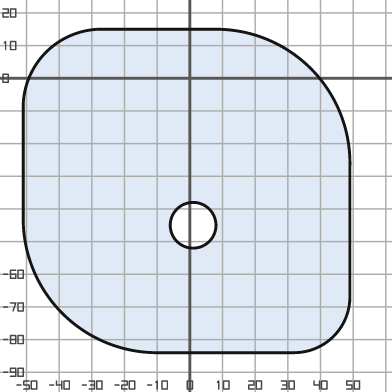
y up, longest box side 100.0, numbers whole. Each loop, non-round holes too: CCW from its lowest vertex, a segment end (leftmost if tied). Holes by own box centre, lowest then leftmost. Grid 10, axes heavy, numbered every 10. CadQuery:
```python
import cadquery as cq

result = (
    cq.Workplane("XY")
    .moveTo(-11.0, -84.0)
    .lineTo(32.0, -84.0)
    .threePointArc((44.0, -79.0), (49.0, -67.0))
    .lineTo(49.0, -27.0)
    .threePointArc((37.0, 3.0), (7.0, 15.0))
    .lineTo(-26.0, 15.0)
    .threePointArc((-44.0, 8.0), (-51.0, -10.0))
    .lineTo(-51.0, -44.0)
    .threePointArc((-39.0, -72.0), (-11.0, -84.0))
    .close()
    .moveTo(1.0, -45.0)
    .circle(7.0)
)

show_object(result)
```